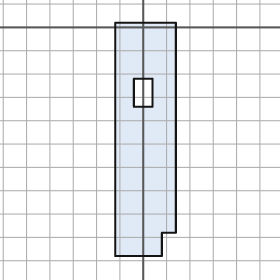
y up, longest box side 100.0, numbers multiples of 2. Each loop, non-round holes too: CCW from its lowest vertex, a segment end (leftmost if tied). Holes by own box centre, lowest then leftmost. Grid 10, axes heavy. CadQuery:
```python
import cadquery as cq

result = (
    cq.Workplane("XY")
    .moveTo(-12.0, -98.0)
    .lineTo(8.0, -98.0)
    .lineTo(8.0, -88.0)
    .lineTo(14.0, -88.0)
    .lineTo(14.0, 2.0)
    .lineTo(-12.0, 2.0)
    .close()
    .moveTo(-4.0, -34.0)
    .lineTo(4.0, -34.0)
    .lineTo(4.0, -22.0)
    .lineTo(-4.0, -22.0)
    .close()
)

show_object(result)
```